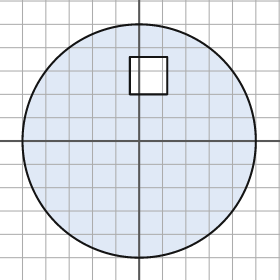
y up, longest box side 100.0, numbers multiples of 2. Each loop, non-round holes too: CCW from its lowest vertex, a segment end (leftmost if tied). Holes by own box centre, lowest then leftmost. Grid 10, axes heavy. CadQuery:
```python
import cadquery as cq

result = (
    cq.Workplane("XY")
    .moveTo(0.0, 0.0)
    .circle(50.0)
    .moveTo(-4.0, 20.0)
    .lineTo(12.0, 20.0)
    .lineTo(12.0, 36.0)
    .lineTo(-4.0, 36.0)
    .close()
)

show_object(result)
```